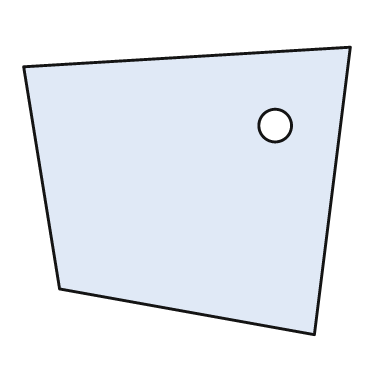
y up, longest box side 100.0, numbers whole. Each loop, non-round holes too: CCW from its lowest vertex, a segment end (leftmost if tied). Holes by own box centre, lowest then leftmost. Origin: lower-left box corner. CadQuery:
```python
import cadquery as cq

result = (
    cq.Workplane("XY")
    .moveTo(89.0, 0.0)
    .lineTo(100.0, 88.0)
    .lineTo(0.0, 82.0)
    .lineTo(11.0, 14.0)
    .close()
    .moveTo(77.0, 64.0)
    .circle(5.0)
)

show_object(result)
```